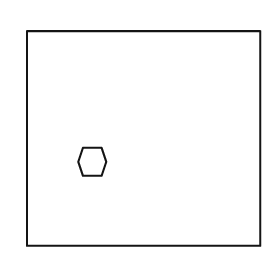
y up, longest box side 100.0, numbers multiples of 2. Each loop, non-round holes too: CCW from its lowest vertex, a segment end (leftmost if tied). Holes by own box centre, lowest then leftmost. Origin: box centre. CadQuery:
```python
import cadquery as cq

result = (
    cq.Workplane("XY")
    .moveTo(-50.0, -46.0)
    .lineTo(50.0, -46.0)
    .lineTo(50.0, 46.0)
    .lineTo(-50.0, 46.0)
    .close()
    .moveTo(-26.0, -16.0)
    .lineTo(-18.0, -16.0)
    .lineTo(-16.0, -10.0)
    .lineTo(-18.0, -4.0)
    .lineTo(-26.0, -4.0)
    .lineTo(-28.0, -10.0)
    .close()
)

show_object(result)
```